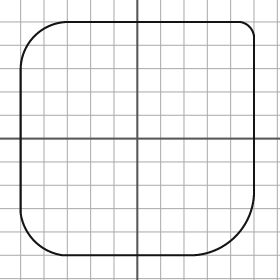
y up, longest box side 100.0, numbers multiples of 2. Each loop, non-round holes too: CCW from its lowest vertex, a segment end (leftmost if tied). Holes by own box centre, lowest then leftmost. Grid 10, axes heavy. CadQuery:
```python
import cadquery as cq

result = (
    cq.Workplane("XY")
    .moveTo(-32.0, -50.0)
    .lineTo(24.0, -50.0)
    .threePointArc((42.0, -42.0), (50.0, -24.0))
    .lineTo(50.0, 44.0)
    .threePointArc((48.0, 48.0), (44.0, 50.0))
    .lineTo(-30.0, 50.0)
    .threePointArc((-44.0, 44.0), (-50.0, 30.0))
    .lineTo(-50.0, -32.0)
    .threePointArc((-44.0, -44.0), (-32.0, -50.0))
    .close()
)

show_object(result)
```